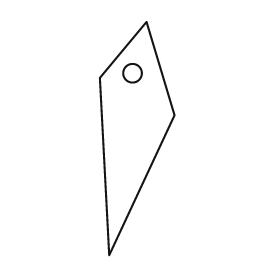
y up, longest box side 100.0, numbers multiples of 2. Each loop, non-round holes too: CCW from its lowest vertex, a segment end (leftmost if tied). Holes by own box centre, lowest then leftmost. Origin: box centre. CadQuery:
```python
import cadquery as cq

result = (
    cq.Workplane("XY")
    .moveTo(-12.0, -50.0)
    .lineTo(16.0, 10.0)
    .lineTo(4.0, 50.0)
    .lineTo(-16.0, 26.0)
    .close()
    .moveTo(-2.0, 28.0)
    .circle(4.0)
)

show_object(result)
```